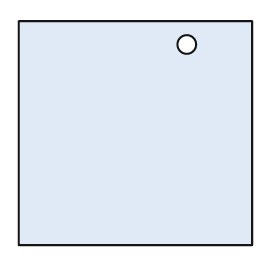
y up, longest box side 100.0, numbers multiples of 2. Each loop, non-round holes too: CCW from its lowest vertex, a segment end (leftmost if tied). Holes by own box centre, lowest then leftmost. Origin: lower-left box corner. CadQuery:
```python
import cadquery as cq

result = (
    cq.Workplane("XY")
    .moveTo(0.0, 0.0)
    .lineTo(100.0, 0.0)
    .lineTo(100.0, 96.0)
    .lineTo(0.0, 96.0)
    .close()
    .moveTo(72.0, 86.0)
    .circle(4.0)
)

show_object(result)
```